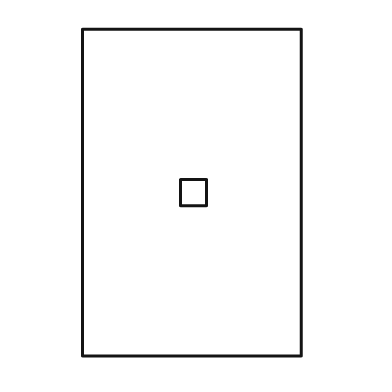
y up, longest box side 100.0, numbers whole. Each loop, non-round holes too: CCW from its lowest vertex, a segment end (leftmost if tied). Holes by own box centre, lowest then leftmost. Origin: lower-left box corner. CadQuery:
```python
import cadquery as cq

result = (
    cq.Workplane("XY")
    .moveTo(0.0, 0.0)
    .lineTo(67.0, 0.0)
    .lineTo(67.0, 100.0)
    .lineTo(0.0, 100.0)
    .close()
    .moveTo(30.0, 46.0)
    .lineTo(38.0, 46.0)
    .lineTo(38.0, 54.0)
    .lineTo(30.0, 54.0)
    .close()
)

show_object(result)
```